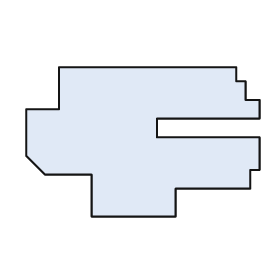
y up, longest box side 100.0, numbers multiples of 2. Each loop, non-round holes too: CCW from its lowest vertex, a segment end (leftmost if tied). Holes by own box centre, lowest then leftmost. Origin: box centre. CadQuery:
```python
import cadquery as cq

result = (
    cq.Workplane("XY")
    .moveTo(-22.0, -32.0)
    .lineTo(14.0, -32.0)
    .lineTo(14.0, -20.0)
    .lineTo(46.0, -20.0)
    .lineTo(46.0, -12.0)
    .lineTo(50.0, -12.0)
    .lineTo(50.0, 2.0)
    .lineTo(6.0, 2.0)
    .lineTo(6.0, 10.0)
    .lineTo(50.0, 10.0)
    .lineTo(50.0, 18.0)
    .lineTo(44.0, 18.0)
    .lineTo(44.0, 26.0)
    .lineTo(40.0, 26.0)
    .lineTo(40.0, 32.0)
    .lineTo(-36.0, 32.0)
    .lineTo(-36.0, 14.0)
    .lineTo(-50.0, 14.0)
    .lineTo(-50.0, -6.0)
    .lineTo(-42.0, -14.0)
    .lineTo(-22.0, -14.0)
    .close()
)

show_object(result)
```